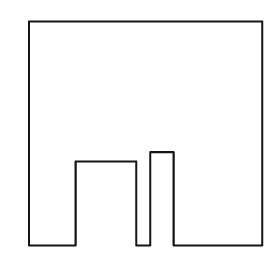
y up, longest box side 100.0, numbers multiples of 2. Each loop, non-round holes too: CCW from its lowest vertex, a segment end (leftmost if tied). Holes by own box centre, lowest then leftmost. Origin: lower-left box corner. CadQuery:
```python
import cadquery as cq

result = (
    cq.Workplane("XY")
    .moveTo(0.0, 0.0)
    .lineTo(20.0, 0.0)
    .lineTo(20.0, 36.0)
    .lineTo(46.0, 36.0)
    .lineTo(46.0, 0.0)
    .lineTo(52.0, 0.0)
    .lineTo(52.0, 40.0)
    .lineTo(62.0, 40.0)
    .lineTo(62.0, 0.0)
    .lineTo(100.0, 0.0)
    .lineTo(100.0, 96.0)
    .lineTo(0.0, 96.0)
    .close()
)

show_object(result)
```